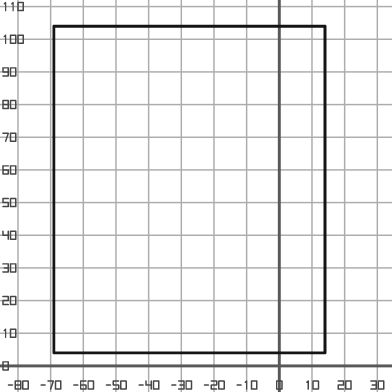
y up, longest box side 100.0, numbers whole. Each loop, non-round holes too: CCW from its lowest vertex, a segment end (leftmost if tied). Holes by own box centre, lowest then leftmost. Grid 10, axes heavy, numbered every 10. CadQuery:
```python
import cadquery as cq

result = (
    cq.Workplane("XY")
    .moveTo(-69.0, 4.0)
    .lineTo(14.0, 4.0)
    .lineTo(14.0, 104.0)
    .lineTo(-69.0, 104.0)
    .close()
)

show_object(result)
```